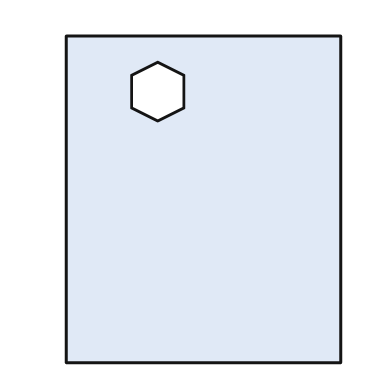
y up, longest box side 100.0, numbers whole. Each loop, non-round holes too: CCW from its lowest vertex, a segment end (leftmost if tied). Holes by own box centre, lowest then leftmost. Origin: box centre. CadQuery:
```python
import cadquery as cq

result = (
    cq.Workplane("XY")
    .moveTo(-42.0, -50.0)
    .lineTo(42.0, -50.0)
    .lineTo(42.0, 50.0)
    .lineTo(-42.0, 50.0)
    .close()
    .moveTo(-14.0, 24.0)
    .lineTo(-6.0, 28.0)
    .lineTo(-6.0, 38.0)
    .lineTo(-14.0, 42.0)
    .lineTo(-22.0, 38.0)
    .lineTo(-22.0, 28.0)
    .close()
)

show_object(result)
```